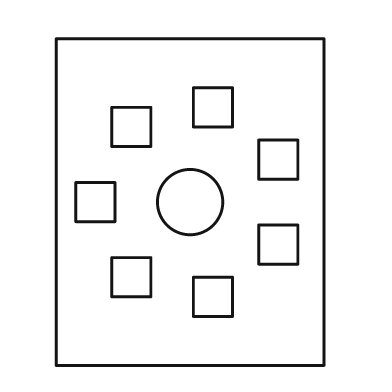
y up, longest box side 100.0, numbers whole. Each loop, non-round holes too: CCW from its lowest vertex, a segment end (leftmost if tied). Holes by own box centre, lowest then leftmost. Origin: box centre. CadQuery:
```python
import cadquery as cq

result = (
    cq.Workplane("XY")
    .moveTo(-41.0, -50.0)
    .lineTo(41.0, -50.0)
    .lineTo(41.0, 50.0)
    .lineTo(-41.0, 50.0)
    .close()
    .moveTo(1.0, -35.0)
    .lineTo(13.0, -35.0)
    .lineTo(13.0, -23.0)
    .lineTo(1.0, -23.0)
    .close()
    .moveTo(-24.0, -29.0)
    .lineTo(-12.0, -29.0)
    .lineTo(-12.0, -17.0)
    .lineTo(-24.0, -17.0)
    .close()
    .moveTo(21.0, -19.0)
    .lineTo(33.0, -19.0)
    .lineTo(33.0, -7.0)
    .lineTo(21.0, -7.0)
    .close()
    .moveTo(-35.0, -6.0)
    .lineTo(-23.0, -6.0)
    .lineTo(-23.0, 6.0)
    .lineTo(-35.0, 6.0)
    .close()
    .moveTo(0.0, 0.0)
    .circle(10.0)
    .moveTo(21.0, 7.0)
    .lineTo(33.0, 7.0)
    .lineTo(33.0, 19.0)
    .lineTo(21.0, 19.0)
    .close()
    .moveTo(-24.0, 17.0)
    .lineTo(-12.0, 17.0)
    .lineTo(-12.0, 29.0)
    .lineTo(-24.0, 29.0)
    .close()
    .moveTo(1.0, 23.0)
    .lineTo(13.0, 23.0)
    .lineTo(13.0, 35.0)
    .lineTo(1.0, 35.0)
    .close()
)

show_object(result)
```